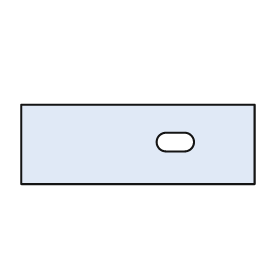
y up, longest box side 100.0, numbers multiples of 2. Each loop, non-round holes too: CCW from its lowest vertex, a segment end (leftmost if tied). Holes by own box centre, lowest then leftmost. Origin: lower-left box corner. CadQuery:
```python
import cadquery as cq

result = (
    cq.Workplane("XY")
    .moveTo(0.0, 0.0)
    .lineTo(100.0, 0.0)
    .lineTo(100.0, 34.0)
    .lineTo(0.0, 34.0)
    .close()
    .moveTo(62.0, 14.0)
    .lineTo(70.0, 14.0)
    .threePointArc((74.0, 18.0), (70.0, 22.0))
    .lineTo(62.0, 22.0)
    .threePointArc((58.0, 18.0), (62.0, 14.0))
    .close()
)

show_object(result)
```